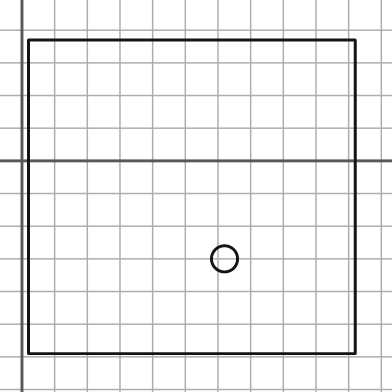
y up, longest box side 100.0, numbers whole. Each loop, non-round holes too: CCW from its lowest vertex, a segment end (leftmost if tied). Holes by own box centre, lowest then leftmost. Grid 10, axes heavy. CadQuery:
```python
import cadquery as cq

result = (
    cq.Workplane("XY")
    .moveTo(2.0, -59.0)
    .lineTo(102.0, -59.0)
    .lineTo(102.0, 37.0)
    .lineTo(2.0, 37.0)
    .close()
    .moveTo(62.0, -30.0)
    .circle(4.0)
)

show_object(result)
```